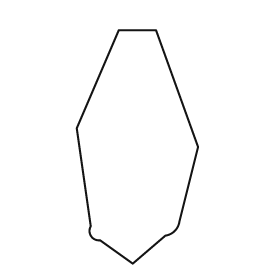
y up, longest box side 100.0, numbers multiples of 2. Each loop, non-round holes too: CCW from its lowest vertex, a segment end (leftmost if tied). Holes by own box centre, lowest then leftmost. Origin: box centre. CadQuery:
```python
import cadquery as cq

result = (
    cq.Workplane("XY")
    .moveTo(-2.0, -50.0)
    .lineTo(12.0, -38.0)
    .threePointArc((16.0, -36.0), (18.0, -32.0))
    .lineTo(26.0, 0.0)
    .lineTo(8.0, 50.0)
    .lineTo(-8.0, 50.0)
    .lineTo(-26.0, 8.0)
    .lineTo(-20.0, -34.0)
    .threePointArc((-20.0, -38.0), (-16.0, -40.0))
    .close()
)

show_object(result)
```